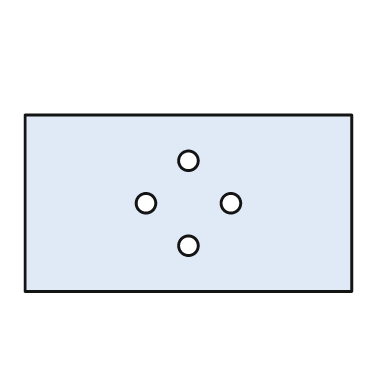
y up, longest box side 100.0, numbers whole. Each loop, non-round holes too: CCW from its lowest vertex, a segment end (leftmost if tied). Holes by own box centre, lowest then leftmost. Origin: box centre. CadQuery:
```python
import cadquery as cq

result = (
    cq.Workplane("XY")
    .moveTo(-50.0, -27.0)
    .lineTo(50.0, -27.0)
    .lineTo(50.0, 27.0)
    .lineTo(-50.0, 27.0)
    .close()
    .moveTo(0.0, -13.0)
    .circle(3.0)
    .moveTo(-13.0, 0.0)
    .circle(3.0)
    .moveTo(13.0, 0.0)
    .circle(3.0)
    .moveTo(0.0, 13.0)
    .circle(3.0)
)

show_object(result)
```